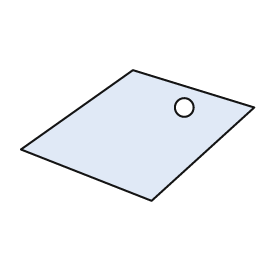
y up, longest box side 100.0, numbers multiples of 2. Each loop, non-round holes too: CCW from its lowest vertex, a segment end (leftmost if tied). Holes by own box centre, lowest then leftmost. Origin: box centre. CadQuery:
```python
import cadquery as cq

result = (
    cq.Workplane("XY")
    .moveTo(6.0, -28.0)
    .lineTo(50.0, 12.0)
    .lineTo(-2.0, 28.0)
    .lineTo(-50.0, -6.0)
    .close()
    .moveTo(20.0, 12.0)
    .circle(4.0)
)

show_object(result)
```